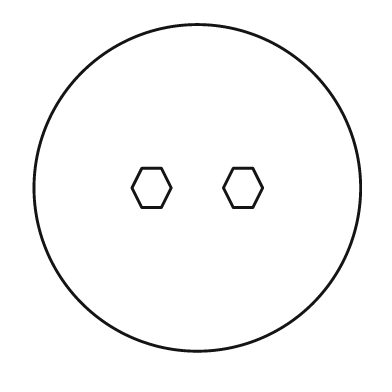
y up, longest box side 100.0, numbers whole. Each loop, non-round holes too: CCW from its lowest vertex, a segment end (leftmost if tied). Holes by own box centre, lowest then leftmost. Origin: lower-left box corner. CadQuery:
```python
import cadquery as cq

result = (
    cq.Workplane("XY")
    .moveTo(50.0, 50.0)
    .circle(50.0)
    .moveTo(33.0, 44.0)
    .lineTo(39.0, 44.0)
    .lineTo(42.0, 50.0)
    .lineTo(39.0, 56.0)
    .lineTo(33.0, 56.0)
    .lineTo(30.0, 50.0)
    .close()
    .moveTo(61.0, 44.0)
    .lineTo(67.0, 44.0)
    .lineTo(70.0, 50.0)
    .lineTo(67.0, 56.0)
    .lineTo(61.0, 56.0)
    .lineTo(58.0, 50.0)
    .close()
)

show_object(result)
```